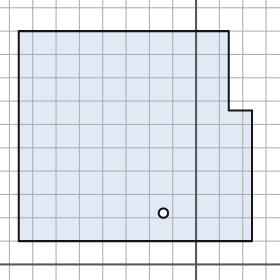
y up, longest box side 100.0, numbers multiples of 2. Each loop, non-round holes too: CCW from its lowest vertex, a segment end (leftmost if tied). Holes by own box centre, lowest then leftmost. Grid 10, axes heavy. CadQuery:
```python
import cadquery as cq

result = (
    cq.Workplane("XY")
    .moveTo(-76.0, 10.0)
    .lineTo(24.0, 10.0)
    .lineTo(24.0, 66.0)
    .lineTo(14.0, 66.0)
    .lineTo(14.0, 100.0)
    .lineTo(-76.0, 100.0)
    .close()
    .moveTo(-14.0, 22.0)
    .circle(2.0)
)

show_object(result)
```